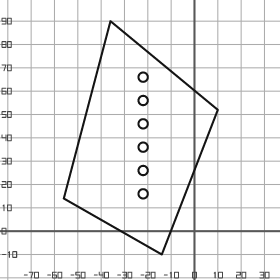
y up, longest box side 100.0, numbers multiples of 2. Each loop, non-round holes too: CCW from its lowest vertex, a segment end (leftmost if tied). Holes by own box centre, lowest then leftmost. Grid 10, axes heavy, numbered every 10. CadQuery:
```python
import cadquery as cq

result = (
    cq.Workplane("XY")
    .moveTo(-14.0, -10.0)
    .lineTo(10.0, 52.0)
    .lineTo(-36.0, 90.0)
    .lineTo(-56.0, 14.0)
    .close()
    .moveTo(-22.0, 16.0)
    .circle(2.0)
    .moveTo(-22.0, 26.0)
    .circle(2.0)
    .moveTo(-22.0, 36.0)
    .circle(2.0)
    .moveTo(-22.0, 46.0)
    .circle(2.0)
    .moveTo(-22.0, 56.0)
    .circle(2.0)
    .moveTo(-22.0, 66.0)
    .circle(2.0)
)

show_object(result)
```